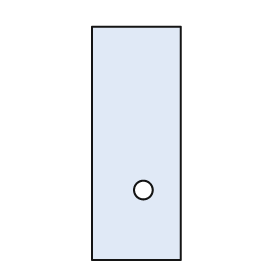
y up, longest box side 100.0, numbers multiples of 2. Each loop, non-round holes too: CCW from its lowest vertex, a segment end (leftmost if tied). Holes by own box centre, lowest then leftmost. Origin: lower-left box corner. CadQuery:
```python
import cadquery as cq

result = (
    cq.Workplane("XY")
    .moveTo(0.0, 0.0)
    .lineTo(38.0, 0.0)
    .lineTo(38.0, 100.0)
    .lineTo(0.0, 100.0)
    .close()
    .moveTo(22.0, 30.0)
    .circle(4.0)
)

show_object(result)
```